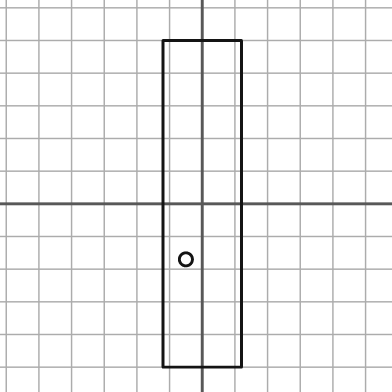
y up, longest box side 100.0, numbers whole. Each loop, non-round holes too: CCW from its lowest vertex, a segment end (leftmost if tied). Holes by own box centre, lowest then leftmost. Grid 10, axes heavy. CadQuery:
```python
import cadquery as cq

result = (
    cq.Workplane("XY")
    .moveTo(-12.0, -50.0)
    .lineTo(12.0, -50.0)
    .lineTo(12.0, 50.0)
    .lineTo(-12.0, 50.0)
    .close()
    .moveTo(-5.0, -17.0)
    .circle(2.0)
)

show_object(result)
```